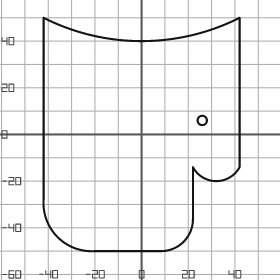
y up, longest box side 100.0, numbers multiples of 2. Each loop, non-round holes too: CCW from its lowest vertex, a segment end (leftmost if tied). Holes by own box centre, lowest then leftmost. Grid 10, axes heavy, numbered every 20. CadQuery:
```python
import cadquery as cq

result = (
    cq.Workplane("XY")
    .moveTo(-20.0, -50.0)
    .lineTo(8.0, -50.0)
    .threePointArc((18.0, -46.0), (22.0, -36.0))
    .lineTo(22.0, -14.0)
    .threePointArc((32.0, -20.0), (42.0, -14.0))
    .lineTo(42.0, 50.0)
    .threePointArc((0.0, 40.0), (-42.0, 50.0))
    .lineTo(-42.0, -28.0)
    .threePointArc((-36.0, -44.0), (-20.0, -50.0))
    .close()
    .moveTo(26.0, 6.0)
    .circle(2.0)
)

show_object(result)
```